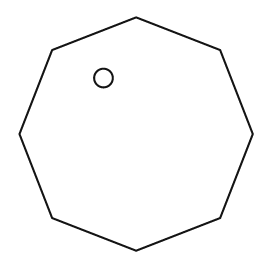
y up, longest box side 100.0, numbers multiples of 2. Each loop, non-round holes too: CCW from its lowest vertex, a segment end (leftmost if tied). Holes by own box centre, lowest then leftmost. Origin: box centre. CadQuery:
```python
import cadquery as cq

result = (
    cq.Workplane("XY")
    .moveTo(0.0, -50.0)
    .lineTo(36.0, -36.0)
    .lineTo(50.0, 0.0)
    .lineTo(36.0, 36.0)
    .lineTo(0.0, 50.0)
    .lineTo(-36.0, 36.0)
    .lineTo(-50.0, 0.0)
    .lineTo(-36.0, -36.0)
    .close()
    .moveTo(-14.0, 24.0)
    .circle(4.0)
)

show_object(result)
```